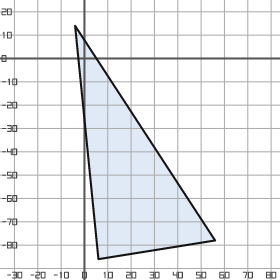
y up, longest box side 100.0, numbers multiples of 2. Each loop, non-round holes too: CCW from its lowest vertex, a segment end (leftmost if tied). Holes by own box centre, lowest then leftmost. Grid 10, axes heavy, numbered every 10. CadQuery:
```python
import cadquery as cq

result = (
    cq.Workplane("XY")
    .moveTo(6.0, -86.0)
    .lineTo(56.0, -78.0)
    .lineTo(-4.0, 14.0)
    .close()
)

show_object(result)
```